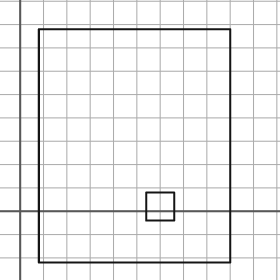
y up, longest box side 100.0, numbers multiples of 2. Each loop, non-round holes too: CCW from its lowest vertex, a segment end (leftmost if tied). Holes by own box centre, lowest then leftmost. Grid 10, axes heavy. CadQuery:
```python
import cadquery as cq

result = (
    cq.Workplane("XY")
    .moveTo(8.0, -22.0)
    .lineTo(90.0, -22.0)
    .lineTo(90.0, 78.0)
    .lineTo(8.0, 78.0)
    .close()
    .moveTo(54.0, -4.0)
    .lineTo(66.0, -4.0)
    .lineTo(66.0, 8.0)
    .lineTo(54.0, 8.0)
    .close()
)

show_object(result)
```